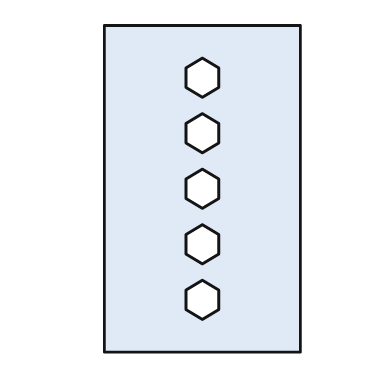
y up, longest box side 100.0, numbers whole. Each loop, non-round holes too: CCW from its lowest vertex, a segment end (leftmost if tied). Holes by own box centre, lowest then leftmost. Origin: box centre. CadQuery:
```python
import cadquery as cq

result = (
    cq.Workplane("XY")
    .moveTo(-30.0, -50.0)
    .lineTo(30.0, -50.0)
    .lineTo(30.0, 50.0)
    .lineTo(-30.0, 50.0)
    .close()
    .moveTo(0.0, -40.0)
    .lineTo(5.0, -37.0)
    .lineTo(5.0, -31.0)
    .lineTo(0.0, -28.0)
    .lineTo(-5.0, -31.0)
    .lineTo(-5.0, -37.0)
    .close()
    .moveTo(0.0, -23.0)
    .lineTo(5.0, -20.0)
    .lineTo(5.0, -14.0)
    .lineTo(0.0, -11.0)
    .lineTo(-5.0, -14.0)
    .lineTo(-5.0, -20.0)
    .close()
    .moveTo(0.0, -6.0)
    .lineTo(5.0, -3.0)
    .lineTo(5.0, 3.0)
    .lineTo(0.0, 6.0)
    .lineTo(-5.0, 3.0)
    .lineTo(-5.0, -3.0)
    .close()
    .moveTo(0.0, 11.0)
    .lineTo(5.0, 14.0)
    .lineTo(5.0, 20.0)
    .lineTo(0.0, 23.0)
    .lineTo(-5.0, 20.0)
    .lineTo(-5.0, 14.0)
    .close()
    .moveTo(0.0, 28.0)
    .lineTo(5.0, 31.0)
    .lineTo(5.0, 37.0)
    .lineTo(0.0, 40.0)
    .lineTo(-5.0, 37.0)
    .lineTo(-5.0, 31.0)
    .close()
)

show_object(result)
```